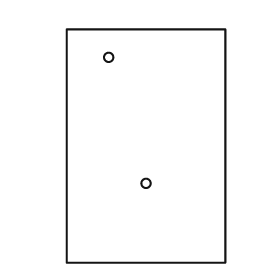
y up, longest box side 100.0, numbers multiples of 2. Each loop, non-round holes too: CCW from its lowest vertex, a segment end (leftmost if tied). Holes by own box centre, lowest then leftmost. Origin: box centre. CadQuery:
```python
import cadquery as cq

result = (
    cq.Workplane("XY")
    .moveTo(-34.0, -50.0)
    .lineTo(34.0, -50.0)
    .lineTo(34.0, 50.0)
    .lineTo(-34.0, 50.0)
    .close()
    .moveTo(0.0, -16.0)
    .circle(2.0)
    .moveTo(-16.0, 38.0)
    .circle(2.0)
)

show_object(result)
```